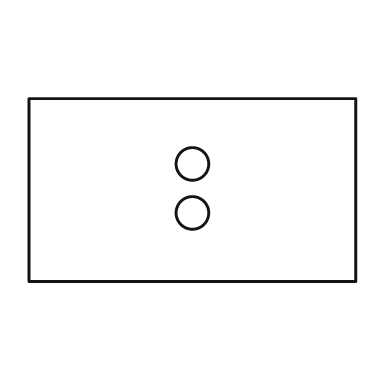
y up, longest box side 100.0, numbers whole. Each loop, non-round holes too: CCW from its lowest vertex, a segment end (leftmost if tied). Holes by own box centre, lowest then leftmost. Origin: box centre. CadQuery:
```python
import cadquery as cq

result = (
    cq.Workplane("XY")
    .moveTo(-50.0, -28.0)
    .lineTo(50.0, -28.0)
    .lineTo(50.0, 28.0)
    .lineTo(-50.0, 28.0)
    .close()
    .moveTo(0.0, -7.0)
    .circle(5.0)
    .moveTo(0.0, 8.0)
    .circle(5.0)
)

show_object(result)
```